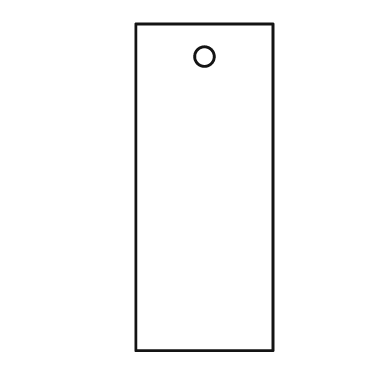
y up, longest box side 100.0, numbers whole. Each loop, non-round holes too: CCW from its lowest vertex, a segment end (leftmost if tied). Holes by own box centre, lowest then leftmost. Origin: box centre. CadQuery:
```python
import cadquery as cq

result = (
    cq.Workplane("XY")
    .moveTo(-21.0, -50.0)
    .lineTo(21.0, -50.0)
    .lineTo(21.0, 50.0)
    .lineTo(-21.0, 50.0)
    .close()
    .moveTo(0.0, 40.0)
    .circle(3.0)
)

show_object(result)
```